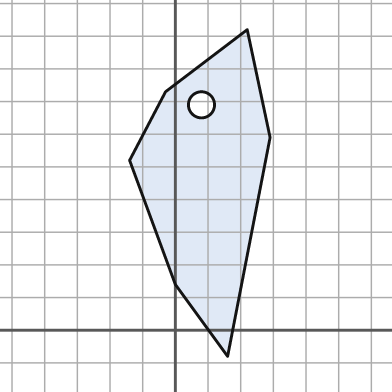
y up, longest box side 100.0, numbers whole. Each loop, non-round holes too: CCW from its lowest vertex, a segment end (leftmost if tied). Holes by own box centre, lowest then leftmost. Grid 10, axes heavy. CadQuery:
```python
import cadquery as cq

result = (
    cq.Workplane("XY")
    .moveTo(16.0, -8.0)
    .lineTo(29.0, 59.0)
    .lineTo(22.0, 92.0)
    .lineTo(-3.0, 73.0)
    .lineTo(-14.0, 52.0)
    .lineTo(0.0, 14.0)
    .close()
    .moveTo(8.0, 69.0)
    .circle(4.0)
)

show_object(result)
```